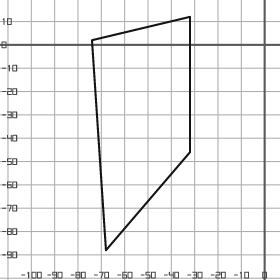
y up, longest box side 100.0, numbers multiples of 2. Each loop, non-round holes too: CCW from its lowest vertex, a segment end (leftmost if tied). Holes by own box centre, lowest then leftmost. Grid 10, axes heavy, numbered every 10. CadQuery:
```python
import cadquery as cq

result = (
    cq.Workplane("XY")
    .moveTo(-68.0, -88.0)
    .lineTo(-32.0, -46.0)
    .lineTo(-32.0, 12.0)
    .lineTo(-74.0, 2.0)
    .close()
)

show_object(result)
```